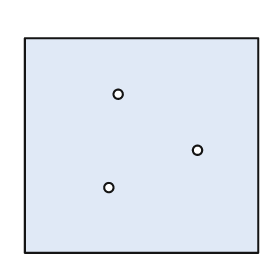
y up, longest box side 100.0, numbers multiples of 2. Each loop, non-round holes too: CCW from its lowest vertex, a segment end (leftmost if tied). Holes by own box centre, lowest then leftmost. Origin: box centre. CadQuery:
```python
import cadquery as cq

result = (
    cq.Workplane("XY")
    .moveTo(-50.0, -46.0)
    .lineTo(50.0, -46.0)
    .lineTo(50.0, 46.0)
    .lineTo(-50.0, 46.0)
    .close()
    .moveTo(-14.0, -18.0)
    .circle(2.0)
    .moveTo(24.0, -2.0)
    .circle(2.0)
    .moveTo(-10.0, 22.0)
    .circle(2.0)
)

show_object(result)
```